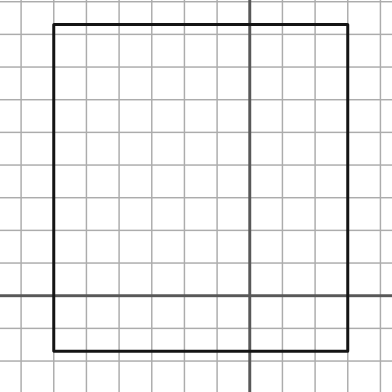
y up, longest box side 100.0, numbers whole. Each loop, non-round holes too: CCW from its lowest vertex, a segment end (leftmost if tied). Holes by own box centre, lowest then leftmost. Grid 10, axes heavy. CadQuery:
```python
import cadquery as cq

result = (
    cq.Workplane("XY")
    .moveTo(-60.0, -17.0)
    .lineTo(30.0, -17.0)
    .lineTo(30.0, 83.0)
    .lineTo(-60.0, 83.0)
    .close()
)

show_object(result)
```